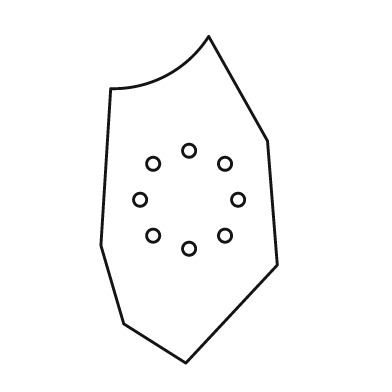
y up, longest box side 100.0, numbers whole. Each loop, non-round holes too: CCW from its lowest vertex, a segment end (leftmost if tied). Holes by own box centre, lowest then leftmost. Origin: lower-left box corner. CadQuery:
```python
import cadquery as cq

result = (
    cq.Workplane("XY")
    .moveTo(26.0, 0.0)
    .lineTo(54.0, 30.0)
    .lineTo(51.0, 68.0)
    .lineTo(33.0, 100.0)
    .threePointArc((20.0, 88.0), (3.0, 84.0))
    .lineTo(0.0, 36.0)
    .lineTo(7.0, 12.0)
    .close()
    .moveTo(27.0, 35.0)
    .circle(2.0)
    .moveTo(16.0, 39.0)
    .circle(2.0)
    .moveTo(38.0, 39.0)
    .circle(2.0)
    .moveTo(12.0, 50.0)
    .circle(2.0)
    .moveTo(42.0, 50.0)
    .circle(2.0)
    .moveTo(16.0, 61.0)
    .circle(2.0)
    .moveTo(38.0, 61.0)
    .circle(2.0)
    .moveTo(27.0, 65.0)
    .circle(2.0)
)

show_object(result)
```